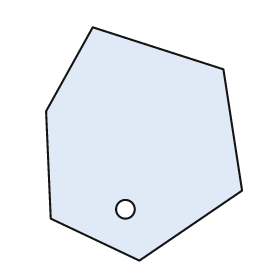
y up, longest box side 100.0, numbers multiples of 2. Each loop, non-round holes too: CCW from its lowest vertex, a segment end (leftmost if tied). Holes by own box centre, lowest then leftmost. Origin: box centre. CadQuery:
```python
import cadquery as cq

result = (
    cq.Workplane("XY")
    .moveTo(-2.0, -50.0)
    .lineTo(42.0, -20.0)
    .lineTo(34.0, 32.0)
    .lineTo(-22.0, 50.0)
    .lineTo(-42.0, 14.0)
    .lineTo(-40.0, -32.0)
    .close()
    .moveTo(-8.0, -28.0)
    .circle(4.0)
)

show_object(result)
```